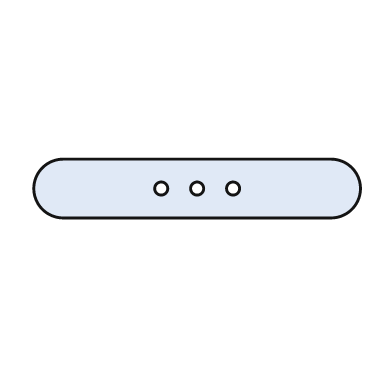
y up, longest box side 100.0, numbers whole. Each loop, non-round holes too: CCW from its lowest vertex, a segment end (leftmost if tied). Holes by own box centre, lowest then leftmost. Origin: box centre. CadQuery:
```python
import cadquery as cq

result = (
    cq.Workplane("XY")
    .moveTo(-41.0, -9.0)
    .lineTo(41.0, -9.0)
    .threePointArc((50.0, 0.0), (41.0, 9.0))
    .lineTo(-41.0, 9.0)
    .threePointArc((-50.0, 0.0), (-41.0, -9.0))
    .close()
    .moveTo(-11.0, 0.0)
    .circle(2.0)
    .moveTo(0.0, 0.0)
    .circle(2.0)
    .moveTo(11.0, 0.0)
    .circle(2.0)
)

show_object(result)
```